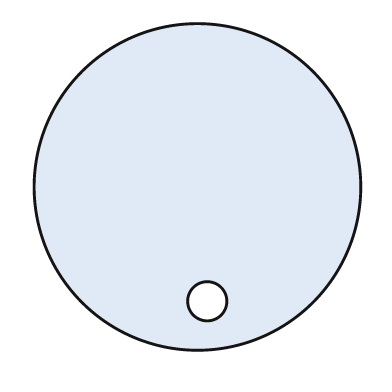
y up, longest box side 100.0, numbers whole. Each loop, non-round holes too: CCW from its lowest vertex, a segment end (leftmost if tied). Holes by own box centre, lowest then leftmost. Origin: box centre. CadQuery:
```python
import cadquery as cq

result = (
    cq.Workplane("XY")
    .moveTo(0.0, 0.0)
    .circle(50.0)
    .moveTo(3.0, -35.0)
    .circle(6.0)
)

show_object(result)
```